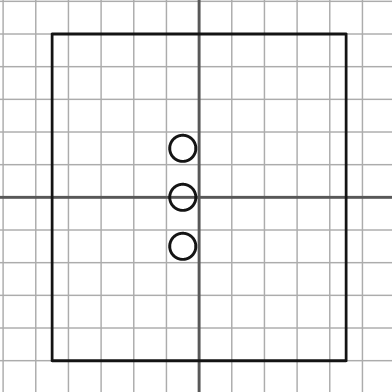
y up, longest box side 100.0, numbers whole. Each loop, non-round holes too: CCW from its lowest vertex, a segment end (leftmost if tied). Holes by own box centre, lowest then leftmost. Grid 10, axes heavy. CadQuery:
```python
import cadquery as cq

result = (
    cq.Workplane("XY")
    .moveTo(-45.0, -50.0)
    .lineTo(45.0, -50.0)
    .lineTo(45.0, 50.0)
    .lineTo(-45.0, 50.0)
    .close()
    .moveTo(-5.0, -15.0)
    .circle(4.0)
    .moveTo(-5.0, 0.0)
    .circle(4.0)
    .moveTo(-5.0, 15.0)
    .circle(4.0)
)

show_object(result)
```